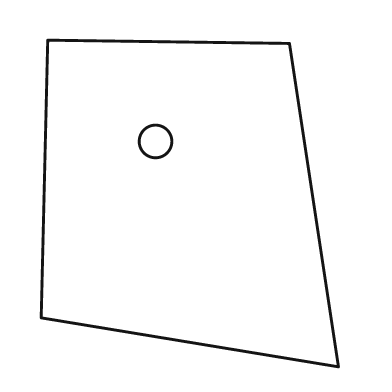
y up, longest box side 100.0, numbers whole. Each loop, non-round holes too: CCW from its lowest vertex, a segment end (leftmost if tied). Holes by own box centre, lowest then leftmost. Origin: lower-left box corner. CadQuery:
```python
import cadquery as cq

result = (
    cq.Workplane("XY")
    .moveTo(91.0, 0.0)
    .lineTo(76.0, 99.0)
    .lineTo(2.0, 100.0)
    .lineTo(0.0, 15.0)
    .close()
    .moveTo(35.0, 69.0)
    .circle(5.0)
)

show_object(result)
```